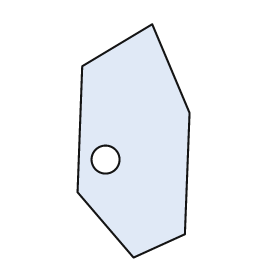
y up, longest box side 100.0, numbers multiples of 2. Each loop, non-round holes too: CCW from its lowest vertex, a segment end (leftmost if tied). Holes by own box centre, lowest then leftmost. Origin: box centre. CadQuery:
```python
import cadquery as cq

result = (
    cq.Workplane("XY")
    .moveTo(0.0, -50.0)
    .lineTo(22.0, -40.0)
    .lineTo(24.0, 12.0)
    .lineTo(8.0, 50.0)
    .lineTo(-22.0, 32.0)
    .lineTo(-24.0, -22.0)
    .close()
    .moveTo(-12.0, -8.0)
    .circle(6.0)
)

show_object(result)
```